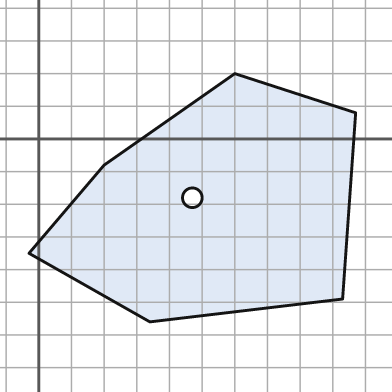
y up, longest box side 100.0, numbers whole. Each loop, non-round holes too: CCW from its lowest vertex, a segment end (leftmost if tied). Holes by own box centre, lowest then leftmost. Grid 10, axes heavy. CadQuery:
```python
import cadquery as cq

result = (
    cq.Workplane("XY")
    .moveTo(34.0, -56.0)
    .lineTo(93.0, -49.0)
    .lineTo(97.0, 8.0)
    .lineTo(60.0, 20.0)
    .lineTo(20.0, -8.0)
    .lineTo(-3.0, -35.0)
    .close()
    .moveTo(47.0, -18.0)
    .circle(3.0)
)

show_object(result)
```